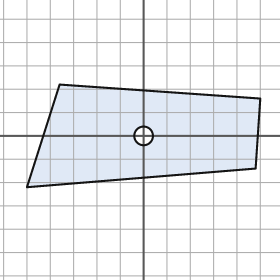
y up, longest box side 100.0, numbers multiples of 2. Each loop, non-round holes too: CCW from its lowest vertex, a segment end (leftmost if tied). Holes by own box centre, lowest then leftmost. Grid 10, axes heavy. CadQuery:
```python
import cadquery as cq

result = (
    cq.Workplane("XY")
    .moveTo(-50.0, -22.0)
    .lineTo(48.0, -14.0)
    .lineTo(50.0, 16.0)
    .lineTo(-36.0, 22.0)
    .close()
    .moveTo(0.0, 0.0)
    .circle(4.0)
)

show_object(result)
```